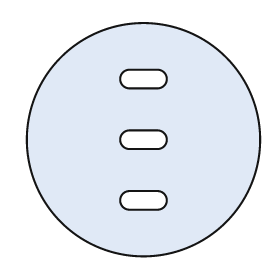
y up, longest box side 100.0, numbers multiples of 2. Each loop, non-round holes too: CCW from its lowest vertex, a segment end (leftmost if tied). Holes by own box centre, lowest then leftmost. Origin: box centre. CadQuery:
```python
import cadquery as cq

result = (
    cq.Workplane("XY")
    .moveTo(0.0, 0.0)
    .circle(50.0)
    .moveTo(-6.0, -30.0)
    .lineTo(6.0, -30.0)
    .threePointArc((10.0, -26.0), (6.0, -22.0))
    .lineTo(-6.0, -22.0)
    .threePointArc((-10.0, -26.0), (-6.0, -30.0))
    .close()
    .moveTo(-6.0, -4.0)
    .lineTo(6.0, -4.0)
    .threePointArc((10.0, 0.0), (6.0, 4.0))
    .lineTo(-6.0, 4.0)
    .threePointArc((-10.0, 0.0), (-6.0, -4.0))
    .close()
    .moveTo(-6.0, 22.0)
    .lineTo(6.0, 22.0)
    .threePointArc((10.0, 26.0), (6.0, 30.0))
    .lineTo(-6.0, 30.0)
    .threePointArc((-10.0, 26.0), (-6.0, 22.0))
    .close()
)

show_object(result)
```